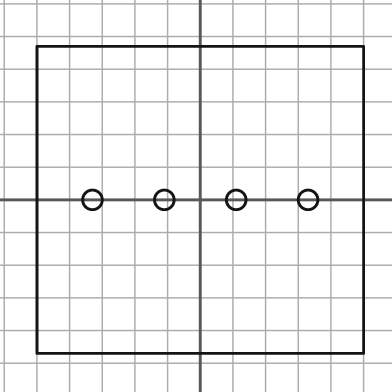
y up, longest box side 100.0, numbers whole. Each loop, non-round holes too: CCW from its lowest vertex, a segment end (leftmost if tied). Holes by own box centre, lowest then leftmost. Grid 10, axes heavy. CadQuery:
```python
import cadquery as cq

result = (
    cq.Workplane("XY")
    .moveTo(-50.0, -47.0)
    .lineTo(50.0, -47.0)
    .lineTo(50.0, 47.0)
    .lineTo(-50.0, 47.0)
    .close()
    .moveTo(-33.0, 0.0)
    .circle(3.0)
    .moveTo(-11.0, 0.0)
    .circle(3.0)
    .moveTo(11.0, 0.0)
    .circle(3.0)
    .moveTo(33.0, 0.0)
    .circle(3.0)
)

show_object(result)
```